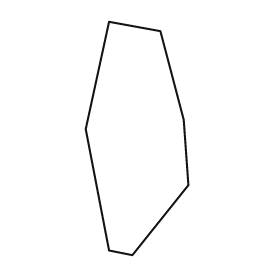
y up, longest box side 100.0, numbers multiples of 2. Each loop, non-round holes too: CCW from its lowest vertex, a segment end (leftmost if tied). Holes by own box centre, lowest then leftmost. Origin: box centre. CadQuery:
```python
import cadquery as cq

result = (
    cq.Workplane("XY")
    .moveTo(-2.0, -50.0)
    .lineTo(22.0, -20.0)
    .lineTo(20.0, 8.0)
    .lineTo(10.0, 46.0)
    .lineTo(-12.0, 50.0)
    .lineTo(-22.0, 4.0)
    .lineTo(-12.0, -48.0)
    .close()
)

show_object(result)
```